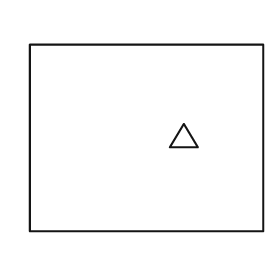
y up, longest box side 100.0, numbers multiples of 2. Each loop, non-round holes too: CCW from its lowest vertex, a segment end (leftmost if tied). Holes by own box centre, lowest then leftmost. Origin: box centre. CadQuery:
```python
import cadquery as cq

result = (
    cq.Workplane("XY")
    .moveTo(-50.0, -40.0)
    .lineTo(50.0, -40.0)
    .lineTo(50.0, 40.0)
    .lineTo(-50.0, 40.0)
    .close()
    .moveTo(10.0, -4.0)
    .lineTo(22.0, -4.0)
    .lineTo(16.0, 6.0)
    .close()
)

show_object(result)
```